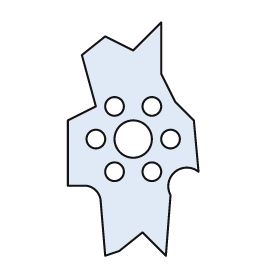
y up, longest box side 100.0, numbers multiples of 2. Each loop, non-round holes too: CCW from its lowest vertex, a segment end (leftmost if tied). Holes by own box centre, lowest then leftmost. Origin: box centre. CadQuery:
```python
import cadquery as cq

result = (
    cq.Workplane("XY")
    .moveTo(-12.0, -50.0)
    .lineTo(-6.0, -48.0)
    .lineTo(4.0, -40.0)
    .lineTo(14.0, -50.0)
    .lineTo(16.0, -24.0)
    .threePointArc((18.0, -14.0), (28.0, -14.0))
    .lineTo(26.0, 8.0)
    .lineTo(18.0, 16.0)
    .lineTo(12.0, 28.0)
    .lineTo(12.0, 50.0)
    .lineTo(0.0, 38.0)
    .lineTo(-12.0, 44.0)
    .lineTo(-22.0, 36.0)
    .lineTo(-16.0, 14.0)
    .lineTo(-28.0, 8.0)
    .lineTo(-28.0, -20.0)
    .lineTo(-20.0, -20.0)
    .threePointArc((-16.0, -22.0), (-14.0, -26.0))
    .close()
    .moveTo(-8.0, -14.0)
    .circle(4.0)
    .moveTo(8.0, -14.0)
    .circle(4.0)
    .moveTo(-16.0, 0.0)
    .circle(4.0)
    .moveTo(0.0, 0.0)
    .circle(8.0)
    .moveTo(16.0, 0.0)
    .circle(4.0)
    .moveTo(-8.0, 14.0)
    .circle(4.0)
    .moveTo(8.0, 14.0)
    .circle(4.0)
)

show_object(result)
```